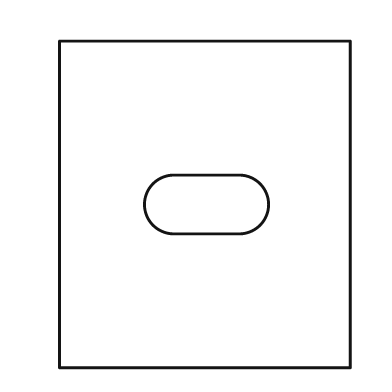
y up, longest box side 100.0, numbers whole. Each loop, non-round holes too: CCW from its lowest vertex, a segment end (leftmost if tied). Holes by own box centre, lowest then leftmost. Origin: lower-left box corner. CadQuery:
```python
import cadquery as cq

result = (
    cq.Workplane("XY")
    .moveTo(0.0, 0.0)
    .lineTo(89.0, 0.0)
    .lineTo(89.0, 100.0)
    .lineTo(0.0, 100.0)
    .close()
    .moveTo(35.0, 41.0)
    .lineTo(55.0, 41.0)
    .threePointArc((64.0, 50.0), (55.0, 59.0))
    .lineTo(35.0, 59.0)
    .threePointArc((26.0, 50.0), (35.0, 41.0))
    .close()
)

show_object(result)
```